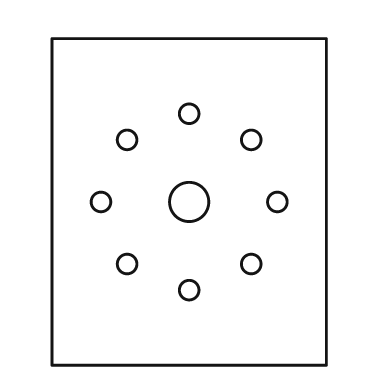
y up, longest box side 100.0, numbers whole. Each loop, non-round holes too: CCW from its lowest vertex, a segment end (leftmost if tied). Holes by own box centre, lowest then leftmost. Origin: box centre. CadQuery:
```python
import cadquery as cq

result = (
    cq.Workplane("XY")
    .moveTo(-42.0, -50.0)
    .lineTo(42.0, -50.0)
    .lineTo(42.0, 50.0)
    .lineTo(-42.0, 50.0)
    .close()
    .moveTo(0.0, -27.0)
    .circle(3.0)
    .moveTo(-19.0, -19.0)
    .circle(3.0)
    .moveTo(19.0, -19.0)
    .circle(3.0)
    .moveTo(-27.0, 0.0)
    .circle(3.0)
    .moveTo(0.0, 0.0)
    .circle(6.0)
    .moveTo(27.0, 0.0)
    .circle(3.0)
    .moveTo(-19.0, 19.0)
    .circle(3.0)
    .moveTo(19.0, 19.0)
    .circle(3.0)
    .moveTo(0.0, 27.0)
    .circle(3.0)
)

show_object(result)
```